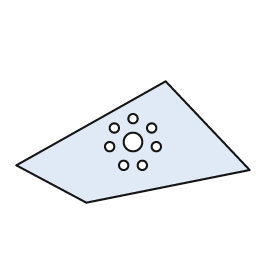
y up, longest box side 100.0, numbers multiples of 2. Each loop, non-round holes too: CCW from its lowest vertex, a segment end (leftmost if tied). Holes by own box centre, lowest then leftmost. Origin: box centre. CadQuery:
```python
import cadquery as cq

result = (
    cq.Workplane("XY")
    .moveTo(-20.0, -26.0)
    .lineTo(50.0, -12.0)
    .lineTo(14.0, 26.0)
    .lineTo(-50.0, -10.0)
    .close()
    .moveTo(-4.0, -10.0)
    .circle(2.0)
    .moveTo(4.0, -10.0)
    .circle(2.0)
    .moveTo(-10.0, -2.0)
    .circle(2.0)
    .moveTo(10.0, -2.0)
    .circle(2.0)
    .moveTo(0.0, 0.0)
    .circle(4.0)
    .moveTo(-8.0, 6.0)
    .circle(2.0)
    .moveTo(8.0, 6.0)
    .circle(2.0)
    .moveTo(0.0, 10.0)
    .circle(2.0)
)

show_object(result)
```